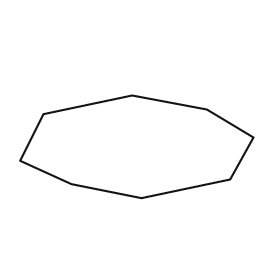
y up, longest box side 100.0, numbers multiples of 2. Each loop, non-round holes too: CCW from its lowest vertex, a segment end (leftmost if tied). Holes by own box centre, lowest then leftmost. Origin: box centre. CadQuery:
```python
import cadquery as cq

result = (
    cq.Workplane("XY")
    .moveTo(2.0, -22.0)
    .lineTo(40.0, -14.0)
    .lineTo(50.0, 4.0)
    .lineTo(30.0, 16.0)
    .lineTo(-2.0, 22.0)
    .lineTo(-40.0, 14.0)
    .lineTo(-50.0, -6.0)
    .lineTo(-28.0, -16.0)
    .close()
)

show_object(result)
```